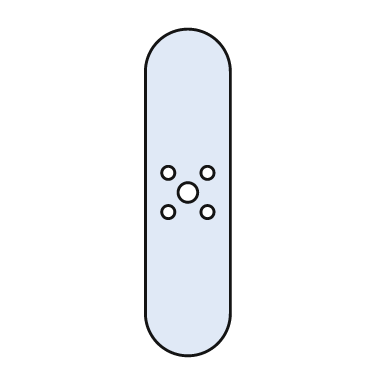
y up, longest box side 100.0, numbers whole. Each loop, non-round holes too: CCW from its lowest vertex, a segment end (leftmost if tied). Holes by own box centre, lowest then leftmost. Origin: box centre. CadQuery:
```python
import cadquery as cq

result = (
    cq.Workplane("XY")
    .moveTo(-13.0, -37.0)
    .threePointArc((0.0, -50.0), (13.0, -37.0))
    .lineTo(13.0, 37.0)
    .threePointArc((0.0, 50.0), (-13.0, 37.0))
    .close()
    .moveTo(-6.0, -6.0)
    .circle(2.0)
    .moveTo(6.0, -6.0)
    .circle(2.0)
    .moveTo(0.0, 0.0)
    .circle(3.0)
    .moveTo(-6.0, 6.0)
    .circle(2.0)
    .moveTo(6.0, 6.0)
    .circle(2.0)
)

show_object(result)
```